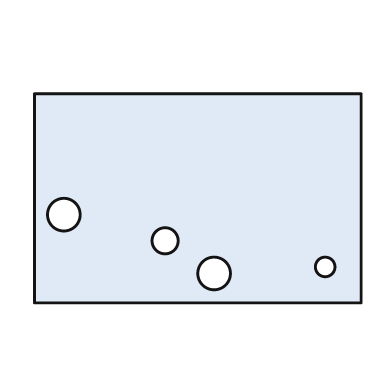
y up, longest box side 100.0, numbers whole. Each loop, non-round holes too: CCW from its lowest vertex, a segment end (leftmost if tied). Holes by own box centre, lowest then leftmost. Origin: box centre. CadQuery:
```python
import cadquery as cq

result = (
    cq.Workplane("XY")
    .moveTo(-50.0, -32.0)
    .lineTo(50.0, -32.0)
    .lineTo(50.0, 32.0)
    .lineTo(-50.0, 32.0)
    .close()
    .moveTo(5.0, -23.0)
    .circle(5.0)
    .moveTo(39.0, -21.0)
    .circle(3.0)
    .moveTo(-10.0, -13.0)
    .circle(4.0)
    .moveTo(-41.0, -5.0)
    .circle(5.0)
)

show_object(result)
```